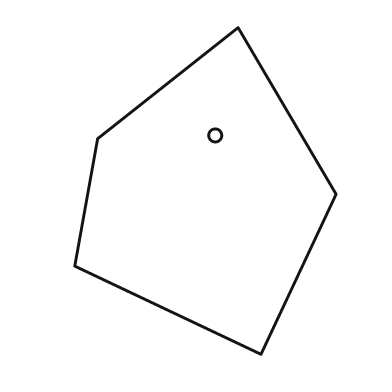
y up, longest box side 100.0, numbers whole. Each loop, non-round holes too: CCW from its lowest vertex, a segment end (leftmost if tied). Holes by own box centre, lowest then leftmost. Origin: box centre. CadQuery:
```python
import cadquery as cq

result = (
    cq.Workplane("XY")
    .moveTo(17.0, -50.0)
    .lineTo(40.0, -1.0)
    .lineTo(10.0, 50.0)
    .lineTo(-33.0, 16.0)
    .lineTo(-40.0, -23.0)
    .close()
    .moveTo(3.0, 17.0)
    .circle(2.0)
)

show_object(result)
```